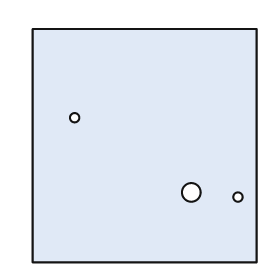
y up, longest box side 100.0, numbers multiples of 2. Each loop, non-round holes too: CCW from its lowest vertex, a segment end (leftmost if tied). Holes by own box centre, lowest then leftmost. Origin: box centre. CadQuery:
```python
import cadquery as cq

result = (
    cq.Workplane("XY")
    .moveTo(-48.0, -50.0)
    .lineTo(48.0, -50.0)
    .lineTo(48.0, 50.0)
    .lineTo(-48.0, 50.0)
    .close()
    .moveTo(40.0, -22.0)
    .circle(2.0)
    .moveTo(20.0, -20.0)
    .circle(4.0)
    .moveTo(-30.0, 12.0)
    .circle(2.0)
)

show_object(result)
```